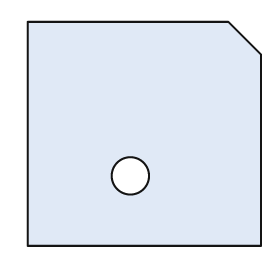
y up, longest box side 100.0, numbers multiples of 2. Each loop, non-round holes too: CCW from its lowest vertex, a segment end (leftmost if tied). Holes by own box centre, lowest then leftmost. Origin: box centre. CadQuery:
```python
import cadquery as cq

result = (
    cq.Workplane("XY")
    .moveTo(-50.0, -48.0)
    .lineTo(50.0, -48.0)
    .lineTo(50.0, 34.0)
    .lineTo(36.0, 48.0)
    .lineTo(-50.0, 48.0)
    .close()
    .moveTo(-6.0, -18.0)
    .circle(8.0)
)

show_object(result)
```